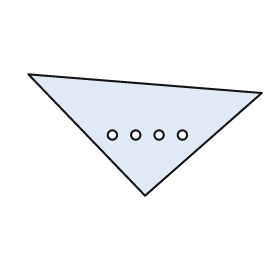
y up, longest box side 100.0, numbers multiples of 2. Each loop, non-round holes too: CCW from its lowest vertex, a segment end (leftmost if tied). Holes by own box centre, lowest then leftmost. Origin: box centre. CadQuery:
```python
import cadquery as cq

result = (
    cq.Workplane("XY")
    .moveTo(0.0, -26.0)
    .lineTo(50.0, 18.0)
    .lineTo(-50.0, 26.0)
    .close()
    .moveTo(-14.0, 0.0)
    .circle(2.0)
    .moveTo(-4.0, 0.0)
    .circle(2.0)
    .moveTo(6.0, 0.0)
    .circle(2.0)
    .moveTo(16.0, 0.0)
    .circle(2.0)
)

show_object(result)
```